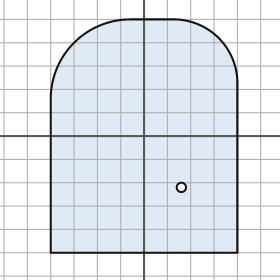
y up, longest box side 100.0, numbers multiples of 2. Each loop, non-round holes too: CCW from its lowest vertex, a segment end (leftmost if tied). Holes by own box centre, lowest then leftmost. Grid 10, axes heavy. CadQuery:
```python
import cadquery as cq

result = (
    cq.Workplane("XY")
    .moveTo(-40.0, -50.0)
    .lineTo(40.0, -50.0)
    .lineTo(40.0, 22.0)
    .threePointArc((32.0, 42.0), (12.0, 50.0))
    .lineTo(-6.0, 50.0)
    .threePointArc((-30.0, 40.0), (-40.0, 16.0))
    .close()
    .moveTo(16.0, -22.0)
    .circle(2.0)
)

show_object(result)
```